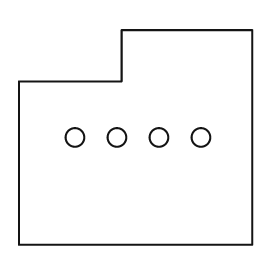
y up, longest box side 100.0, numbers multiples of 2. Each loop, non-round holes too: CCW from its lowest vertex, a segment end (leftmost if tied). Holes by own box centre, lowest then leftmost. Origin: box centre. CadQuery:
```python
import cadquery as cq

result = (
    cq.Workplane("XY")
    .moveTo(-50.0, -46.0)
    .lineTo(50.0, -46.0)
    .lineTo(50.0, 46.0)
    .lineTo(-6.0, 46.0)
    .lineTo(-6.0, 24.0)
    .lineTo(-50.0, 24.0)
    .close()
    .moveTo(-26.0, 0.0)
    .circle(4.0)
    .moveTo(-8.0, 0.0)
    .circle(4.0)
    .moveTo(10.0, 0.0)
    .circle(4.0)
    .moveTo(28.0, 0.0)
    .circle(4.0)
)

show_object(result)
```